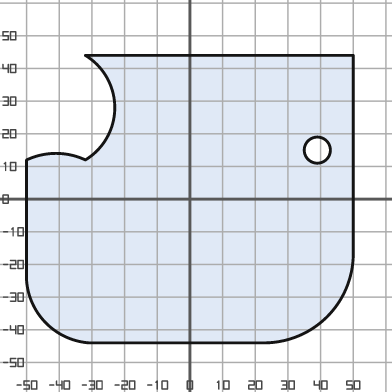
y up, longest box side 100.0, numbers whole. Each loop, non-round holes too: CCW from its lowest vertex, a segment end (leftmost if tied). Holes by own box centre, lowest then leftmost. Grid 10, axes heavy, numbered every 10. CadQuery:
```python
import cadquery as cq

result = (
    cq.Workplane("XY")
    .moveTo(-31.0, -44.0)
    .lineTo(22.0, -44.0)
    .threePointArc((42.0, -36.0), (50.0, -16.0))
    .lineTo(50.0, 44.0)
    .lineTo(-32.0, 44.0)
    .threePointArc((-23.0, 28.0), (-32.0, 12.0))
    .threePointArc((-41.0, 14.0), (-50.0, 12.0))
    .lineTo(-50.0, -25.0)
    .threePointArc((-44.0, -38.0), (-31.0, -44.0))
    .close()
    .moveTo(39.0, 15.0)
    .circle(4.0)
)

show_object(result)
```